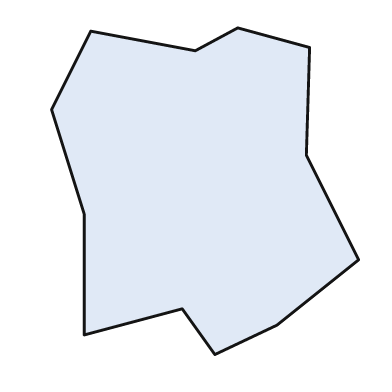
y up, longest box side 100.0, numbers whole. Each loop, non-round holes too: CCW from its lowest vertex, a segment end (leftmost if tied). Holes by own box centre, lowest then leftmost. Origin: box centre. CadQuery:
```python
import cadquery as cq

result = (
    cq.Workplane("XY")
    .moveTo(3.0, -50.0)
    .lineTo(22.0, -41.0)
    .lineTo(47.0, -21.0)
    .lineTo(31.0, 11.0)
    .lineTo(32.0, 44.0)
    .lineTo(10.0, 50.0)
    .lineTo(-3.0, 43.0)
    .lineTo(-35.0, 49.0)
    .lineTo(-47.0, 25.0)
    .lineTo(-37.0, -7.0)
    .lineTo(-37.0, -44.0)
    .lineTo(-7.0, -36.0)
    .close()
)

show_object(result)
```